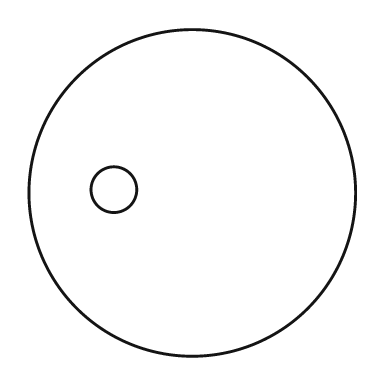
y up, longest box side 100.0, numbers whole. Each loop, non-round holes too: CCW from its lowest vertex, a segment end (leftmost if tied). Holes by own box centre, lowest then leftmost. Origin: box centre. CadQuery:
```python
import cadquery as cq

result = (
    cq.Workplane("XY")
    .moveTo(0.0, 0.0)
    .circle(50.0)
    .moveTo(-24.0, 1.0)
    .circle(7.0)
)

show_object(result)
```